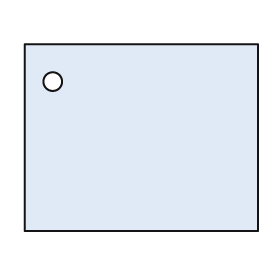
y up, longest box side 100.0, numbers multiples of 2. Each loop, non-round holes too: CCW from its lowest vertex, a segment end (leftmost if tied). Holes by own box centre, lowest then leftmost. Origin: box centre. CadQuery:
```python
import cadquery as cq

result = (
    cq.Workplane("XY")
    .moveTo(-50.0, -40.0)
    .lineTo(50.0, -40.0)
    .lineTo(50.0, 40.0)
    .lineTo(-50.0, 40.0)
    .close()
    .moveTo(-38.0, 24.0)
    .circle(4.0)
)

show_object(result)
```